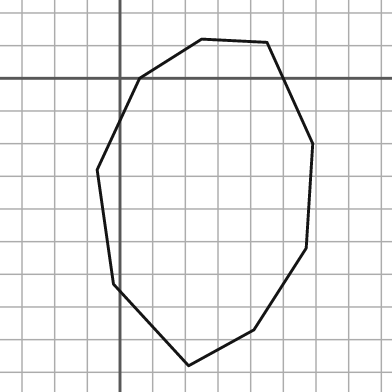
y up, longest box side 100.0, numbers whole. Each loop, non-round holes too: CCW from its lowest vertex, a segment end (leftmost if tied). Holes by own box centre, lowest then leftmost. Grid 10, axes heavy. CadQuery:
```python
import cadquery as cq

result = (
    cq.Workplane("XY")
    .moveTo(21.0, -88.0)
    .lineTo(41.0, -77.0)
    .lineTo(57.0, -52.0)
    .lineTo(59.0, -20.0)
    .lineTo(45.0, 11.0)
    .lineTo(25.0, 12.0)
    .lineTo(6.0, 0.0)
    .lineTo(-7.0, -28.0)
    .lineTo(-2.0, -63.0)
    .close()
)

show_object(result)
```